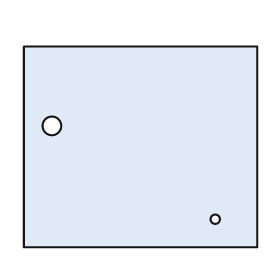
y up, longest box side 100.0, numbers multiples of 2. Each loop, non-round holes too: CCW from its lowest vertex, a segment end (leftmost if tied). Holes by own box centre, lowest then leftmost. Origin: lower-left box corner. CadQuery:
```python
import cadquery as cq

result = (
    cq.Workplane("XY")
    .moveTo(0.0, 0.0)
    .lineTo(100.0, 0.0)
    .lineTo(100.0, 86.0)
    .lineTo(0.0, 86.0)
    .close()
    .moveTo(82.0, 12.0)
    .circle(2.0)
    .moveTo(12.0, 52.0)
    .circle(4.0)
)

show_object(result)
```